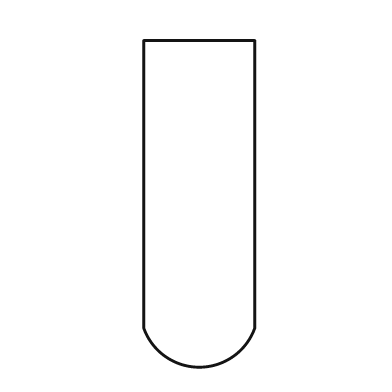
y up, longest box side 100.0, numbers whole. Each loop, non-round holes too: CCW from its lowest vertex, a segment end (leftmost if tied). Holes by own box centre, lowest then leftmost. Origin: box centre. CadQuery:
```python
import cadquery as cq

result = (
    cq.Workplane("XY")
    .moveTo(-17.0, -38.0)
    .threePointArc((0.0, -50.0), (17.0, -38.0))
    .lineTo(17.0, 50.0)
    .lineTo(-17.0, 50.0)
    .close()
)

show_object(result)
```